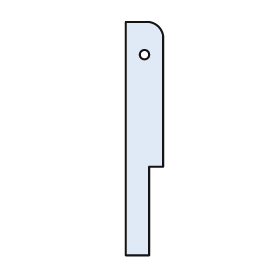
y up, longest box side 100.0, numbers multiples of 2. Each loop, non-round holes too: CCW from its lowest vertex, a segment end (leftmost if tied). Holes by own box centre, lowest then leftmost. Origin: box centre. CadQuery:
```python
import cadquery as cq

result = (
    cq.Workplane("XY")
    .moveTo(-8.0, -50.0)
    .lineTo(2.0, -50.0)
    .lineTo(2.0, -12.0)
    .lineTo(8.0, -12.0)
    .lineTo(8.0, 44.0)
    .threePointArc((6.0, 48.0), (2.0, 50.0))
    .lineTo(-8.0, 50.0)
    .close()
    .moveTo(0.0, 36.0)
    .circle(2.0)
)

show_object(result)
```